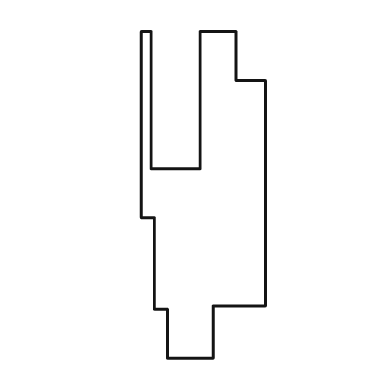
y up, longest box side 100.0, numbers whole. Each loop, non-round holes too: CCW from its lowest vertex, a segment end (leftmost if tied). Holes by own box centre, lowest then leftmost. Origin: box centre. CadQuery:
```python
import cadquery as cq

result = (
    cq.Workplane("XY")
    .moveTo(-11.0, -50.0)
    .lineTo(3.0, -50.0)
    .lineTo(3.0, -34.0)
    .lineTo(19.0, -34.0)
    .lineTo(19.0, 35.0)
    .lineTo(10.0, 35.0)
    .lineTo(10.0, 50.0)
    .lineTo(-1.0, 50.0)
    .lineTo(-1.0, 8.0)
    .lineTo(-16.0, 8.0)
    .lineTo(-16.0, 50.0)
    .lineTo(-19.0, 50.0)
    .lineTo(-19.0, -7.0)
    .lineTo(-15.0, -7.0)
    .lineTo(-15.0, -35.0)
    .lineTo(-11.0, -35.0)
    .close()
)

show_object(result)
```